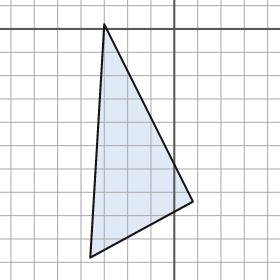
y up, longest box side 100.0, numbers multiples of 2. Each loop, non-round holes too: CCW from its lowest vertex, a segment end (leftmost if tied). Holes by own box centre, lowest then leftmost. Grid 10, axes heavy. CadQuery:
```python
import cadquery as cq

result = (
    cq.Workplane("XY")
    .moveTo(-36.0, -98.0)
    .lineTo(8.0, -74.0)
    .lineTo(-30.0, 2.0)
    .close()
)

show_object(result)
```